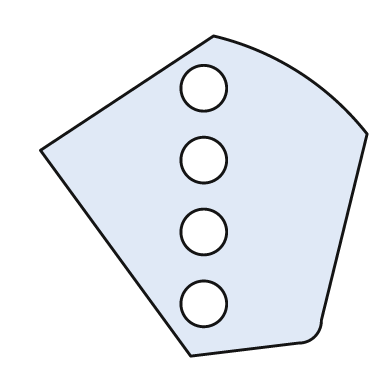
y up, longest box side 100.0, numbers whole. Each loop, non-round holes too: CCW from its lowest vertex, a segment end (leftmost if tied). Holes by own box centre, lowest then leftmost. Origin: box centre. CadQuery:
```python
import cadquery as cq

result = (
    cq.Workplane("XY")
    .moveTo(-4.0, -49.0)
    .lineTo(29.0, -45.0)
    .threePointArc((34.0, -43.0), (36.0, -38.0))
    .lineTo(50.0, 19.0)
    .threePointArc((29.0, 38.0), (3.0, 49.0))
    .lineTo(-50.0, 14.0)
    .close()
    .moveTo(0.0, -33.0)
    .circle(7.0)
    .moveTo(0.0, -11.0)
    .circle(7.0)
    .moveTo(0.0, 11.0)
    .circle(7.0)
    .moveTo(0.0, 33.0)
    .circle(7.0)
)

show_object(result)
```